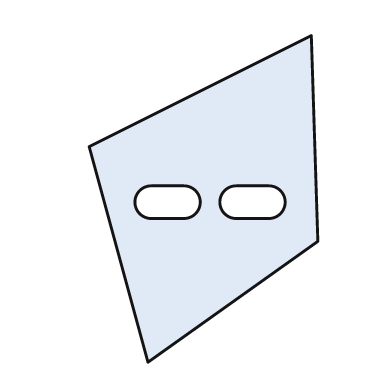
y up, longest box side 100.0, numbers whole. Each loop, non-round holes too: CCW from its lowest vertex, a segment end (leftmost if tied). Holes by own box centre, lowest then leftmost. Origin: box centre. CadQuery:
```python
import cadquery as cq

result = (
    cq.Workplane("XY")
    .moveTo(-17.0, -50.0)
    .lineTo(35.0, -13.0)
    .lineTo(33.0, 50.0)
    .lineTo(-35.0, 16.0)
    .close()
    .moveTo(-16.0, -6.0)
    .lineTo(-6.0, -6.0)
    .threePointArc((-1.0, -1.0), (-6.0, 4.0))
    .lineTo(-16.0, 4.0)
    .threePointArc((-21.0, -1.0), (-16.0, -6.0))
    .close()
    .moveTo(10.0, -6.0)
    .lineTo(20.0, -6.0)
    .threePointArc((25.0, -1.0), (20.0, 4.0))
    .lineTo(10.0, 4.0)
    .threePointArc((5.0, -1.0), (10.0, -6.0))
    .close()
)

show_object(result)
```